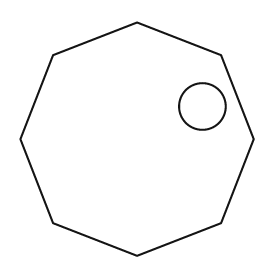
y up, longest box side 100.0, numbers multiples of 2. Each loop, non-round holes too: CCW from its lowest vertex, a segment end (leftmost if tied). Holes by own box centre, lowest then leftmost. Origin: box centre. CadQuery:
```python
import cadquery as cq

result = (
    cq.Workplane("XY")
    .moveTo(0.0, -50.0)
    .lineTo(36.0, -36.0)
    .lineTo(50.0, 0.0)
    .lineTo(36.0, 36.0)
    .lineTo(0.0, 50.0)
    .lineTo(-36.0, 36.0)
    .lineTo(-50.0, 0.0)
    .lineTo(-36.0, -36.0)
    .close()
    .moveTo(28.0, 14.0)
    .circle(10.0)
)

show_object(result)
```